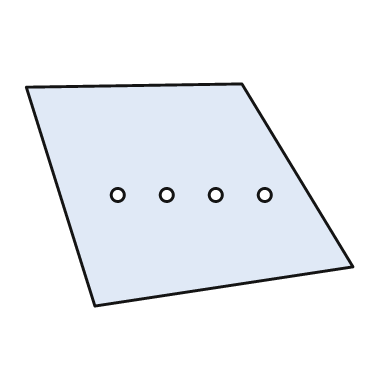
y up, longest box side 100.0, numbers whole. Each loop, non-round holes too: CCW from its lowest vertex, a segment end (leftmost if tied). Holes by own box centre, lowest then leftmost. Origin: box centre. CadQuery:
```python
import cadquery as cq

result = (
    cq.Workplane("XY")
    .moveTo(-29.0, -34.0)
    .lineTo(50.0, -22.0)
    .lineTo(16.0, 34.0)
    .lineTo(-50.0, 33.0)
    .close()
    .moveTo(-22.0, 0.0)
    .circle(2.0)
    .moveTo(-7.0, 0.0)
    .circle(2.0)
    .moveTo(8.0, 0.0)
    .circle(2.0)
    .moveTo(23.0, 0.0)
    .circle(2.0)
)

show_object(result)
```